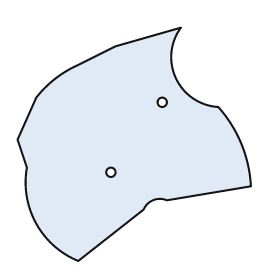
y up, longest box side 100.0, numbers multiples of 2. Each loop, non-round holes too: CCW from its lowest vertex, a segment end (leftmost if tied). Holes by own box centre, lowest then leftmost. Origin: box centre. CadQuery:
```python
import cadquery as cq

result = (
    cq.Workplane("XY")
    .moveTo(-24.0, -50.0)
    .lineTo(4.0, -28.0)
    .threePointArc((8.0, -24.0), (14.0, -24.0))
    .lineTo(50.0, -18.0)
    .threePointArc((46.0, 0.0), (36.0, 16.0))
    .threePointArc((18.0, 28.0), (20.0, 50.0))
    .lineTo(-8.0, 42.0)
    .lineTo(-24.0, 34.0)
    .threePointArc((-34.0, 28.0), (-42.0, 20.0))
    .lineTo(-50.0, 2.0)
    .lineTo(-46.0, -10.0)
    .threePointArc((-42.0, -34.0), (-24.0, -50.0))
    .close()
    .moveTo(-10.0, -12.0)
    .circle(2.0)
    .moveTo(12.0, 18.0)
    .circle(2.0)
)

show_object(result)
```